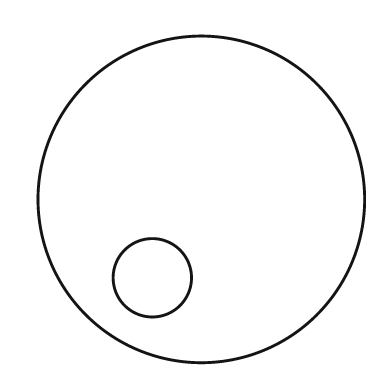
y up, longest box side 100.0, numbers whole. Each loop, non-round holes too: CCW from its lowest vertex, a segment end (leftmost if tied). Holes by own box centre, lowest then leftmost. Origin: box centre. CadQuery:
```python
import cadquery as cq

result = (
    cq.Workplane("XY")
    .moveTo(0.0, 0.0)
    .circle(50.0)
    .moveTo(-15.0, -24.0)
    .circle(12.0)
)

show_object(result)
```